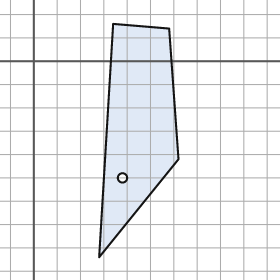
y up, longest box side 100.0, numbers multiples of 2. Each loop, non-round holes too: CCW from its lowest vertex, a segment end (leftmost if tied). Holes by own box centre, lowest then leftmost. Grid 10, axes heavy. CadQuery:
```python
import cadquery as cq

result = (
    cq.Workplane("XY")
    .moveTo(28.0, -84.0)
    .lineTo(62.0, -42.0)
    .lineTo(58.0, 14.0)
    .lineTo(34.0, 16.0)
    .close()
    .moveTo(38.0, -50.0)
    .circle(2.0)
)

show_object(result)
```